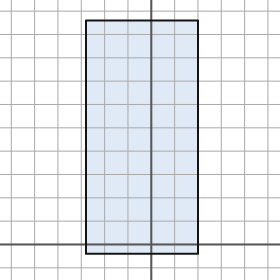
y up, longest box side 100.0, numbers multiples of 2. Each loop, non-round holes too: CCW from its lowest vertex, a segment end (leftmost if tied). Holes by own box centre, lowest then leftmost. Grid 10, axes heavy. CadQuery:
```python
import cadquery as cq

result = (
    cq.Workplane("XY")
    .moveTo(-28.0, -4.0)
    .lineTo(20.0, -4.0)
    .lineTo(20.0, 96.0)
    .lineTo(-28.0, 96.0)
    .close()
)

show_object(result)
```